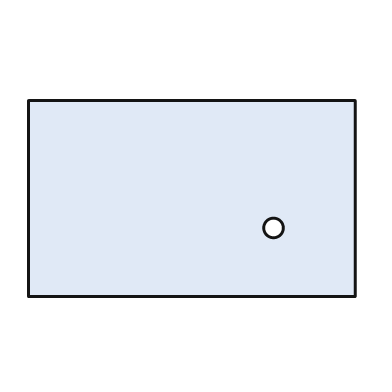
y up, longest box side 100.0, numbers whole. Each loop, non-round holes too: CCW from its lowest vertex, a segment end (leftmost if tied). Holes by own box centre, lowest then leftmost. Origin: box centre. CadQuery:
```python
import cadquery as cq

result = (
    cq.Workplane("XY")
    .moveTo(-50.0, -30.0)
    .lineTo(50.0, -30.0)
    .lineTo(50.0, 30.0)
    .lineTo(-50.0, 30.0)
    .close()
    .moveTo(25.0, -9.0)
    .circle(3.0)
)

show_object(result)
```